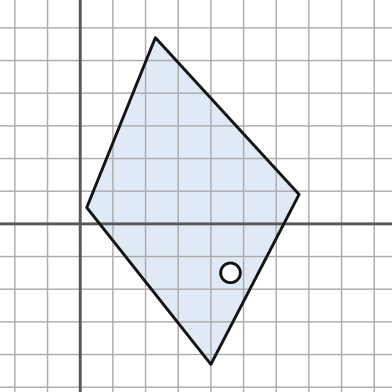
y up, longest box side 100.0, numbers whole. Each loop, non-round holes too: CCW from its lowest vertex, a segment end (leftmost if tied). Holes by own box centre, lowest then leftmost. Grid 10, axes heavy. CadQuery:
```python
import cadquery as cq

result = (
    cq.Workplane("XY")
    .moveTo(40.0, -43.0)
    .lineTo(67.0, 9.0)
    .lineTo(23.0, 57.0)
    .lineTo(2.0, 5.0)
    .close()
    .moveTo(46.0, -15.0)
    .circle(3.0)
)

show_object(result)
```